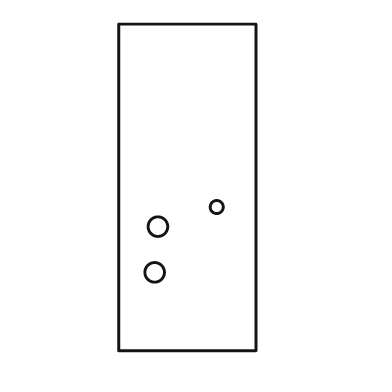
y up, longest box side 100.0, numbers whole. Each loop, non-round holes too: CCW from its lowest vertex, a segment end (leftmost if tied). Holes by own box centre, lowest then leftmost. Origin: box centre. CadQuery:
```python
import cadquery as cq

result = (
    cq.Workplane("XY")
    .moveTo(-21.0, -50.0)
    .lineTo(21.0, -50.0)
    .lineTo(21.0, 50.0)
    .lineTo(-21.0, 50.0)
    .close()
    .moveTo(-10.0, -26.0)
    .circle(3.0)
    .moveTo(-9.0, -12.0)
    .circle(3.0)
    .moveTo(9.0, -6.0)
    .circle(2.0)
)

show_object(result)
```